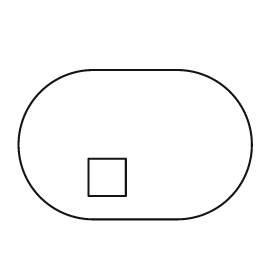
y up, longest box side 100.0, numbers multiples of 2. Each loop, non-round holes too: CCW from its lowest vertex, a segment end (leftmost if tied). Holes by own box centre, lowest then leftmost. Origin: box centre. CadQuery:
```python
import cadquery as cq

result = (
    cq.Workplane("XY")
    .moveTo(-18.0, -32.0)
    .lineTo(18.0, -32.0)
    .threePointArc((50.0, 0.0), (18.0, 32.0))
    .lineTo(-18.0, 32.0)
    .threePointArc((-50.0, 0.0), (-18.0, -32.0))
    .close()
    .moveTo(-20.0, -22.0)
    .lineTo(-4.0, -22.0)
    .lineTo(-4.0, -6.0)
    .lineTo(-20.0, -6.0)
    .close()
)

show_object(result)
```